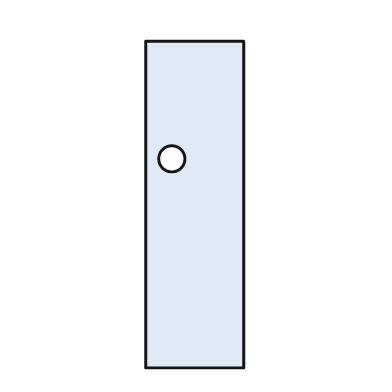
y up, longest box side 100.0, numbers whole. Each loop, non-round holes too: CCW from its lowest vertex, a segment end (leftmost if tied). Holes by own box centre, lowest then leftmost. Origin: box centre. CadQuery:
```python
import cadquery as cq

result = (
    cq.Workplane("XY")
    .moveTo(-15.0, -50.0)
    .lineTo(15.0, -50.0)
    .lineTo(15.0, 50.0)
    .lineTo(-15.0, 50.0)
    .close()
    .moveTo(-7.0, 14.0)
    .circle(4.0)
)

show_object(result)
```